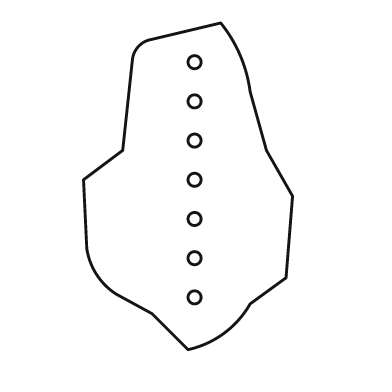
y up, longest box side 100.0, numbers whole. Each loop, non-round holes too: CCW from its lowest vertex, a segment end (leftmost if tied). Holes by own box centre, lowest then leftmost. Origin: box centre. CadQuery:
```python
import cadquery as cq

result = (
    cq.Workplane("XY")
    .moveTo(0.0, -50.0)
    .threePointArc((11.0, -45.0), (19.0, -36.0))
    .lineTo(30.0, -28.0)
    .lineTo(32.0, -3.0)
    .lineTo(24.0, 11.0)
    .lineTo(19.0, 29.0)
    .threePointArc((16.0, 40.0), (10.0, 50.0))
    .lineTo(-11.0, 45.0)
    .threePointArc((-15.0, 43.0), (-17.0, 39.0))
    .lineTo(-20.0, 11.0)
    .lineTo(-32.0, 2.0)
    .lineTo(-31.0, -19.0)
    .threePointArc((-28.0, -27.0), (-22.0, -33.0))
    .lineTo(-11.0, -39.0)
    .close()
    .moveTo(2.0, -34.0)
    .circle(2.0)
    .moveTo(2.0, -22.0)
    .circle(2.0)
    .moveTo(2.0, -10.0)
    .circle(2.0)
    .moveTo(2.0, 2.0)
    .circle(2.0)
    .moveTo(2.0, 14.0)
    .circle(2.0)
    .moveTo(2.0, 26.0)
    .circle(2.0)
    .moveTo(2.0, 38.0)
    .circle(2.0)
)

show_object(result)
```